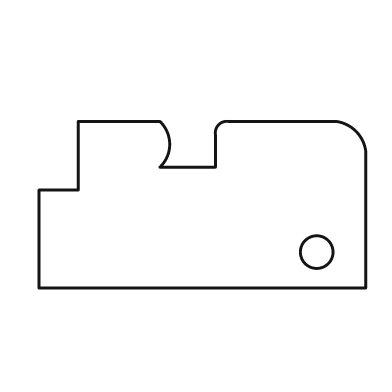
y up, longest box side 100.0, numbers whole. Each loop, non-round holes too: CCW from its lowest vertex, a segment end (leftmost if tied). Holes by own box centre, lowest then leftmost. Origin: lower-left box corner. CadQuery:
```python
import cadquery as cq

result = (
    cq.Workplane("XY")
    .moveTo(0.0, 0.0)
    .lineTo(100.0, 0.0)
    .lineTo(100.0, 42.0)
    .threePointArc((97.0, 48.0), (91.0, 51.0))
    .lineTo(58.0, 51.0)
    .threePointArc((55.0, 50.0), (54.0, 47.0))
    .lineTo(54.0, 37.0)
    .lineTo(37.0, 37.0)
    .threePointArc((40.0, 44.0), (37.0, 51.0))
    .lineTo(12.0, 51.0)
    .lineTo(12.0, 30.0)
    .lineTo(0.0, 30.0)
    .close()
    .moveTo(85.0, 11.0)
    .circle(5.0)
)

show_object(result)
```